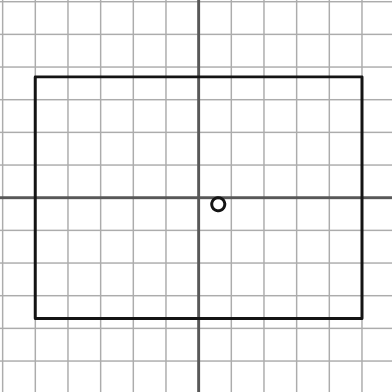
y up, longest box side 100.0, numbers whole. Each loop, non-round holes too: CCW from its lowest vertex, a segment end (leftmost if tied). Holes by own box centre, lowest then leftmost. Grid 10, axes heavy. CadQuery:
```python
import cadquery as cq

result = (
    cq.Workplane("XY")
    .moveTo(-50.0, -37.0)
    .lineTo(50.0, -37.0)
    .lineTo(50.0, 37.0)
    .lineTo(-50.0, 37.0)
    .close()
    .moveTo(6.0, -2.0)
    .circle(2.0)
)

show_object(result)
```